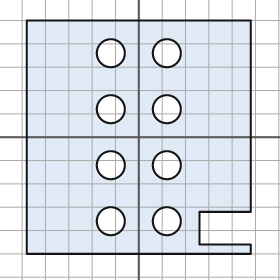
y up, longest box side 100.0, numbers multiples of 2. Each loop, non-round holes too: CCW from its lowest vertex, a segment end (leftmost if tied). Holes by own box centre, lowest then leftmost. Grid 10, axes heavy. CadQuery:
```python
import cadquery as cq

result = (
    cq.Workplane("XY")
    .moveTo(-48.0, -50.0)
    .lineTo(48.0, -50.0)
    .lineTo(48.0, -46.0)
    .lineTo(26.0, -46.0)
    .lineTo(26.0, -32.0)
    .lineTo(48.0, -32.0)
    .lineTo(48.0, 50.0)
    .lineTo(-48.0, 50.0)
    .close()
    .moveTo(-12.0, -36.0)
    .circle(6.0)
    .moveTo(12.0, -36.0)
    .circle(6.0)
    .moveTo(-12.0, -12.0)
    .circle(6.0)
    .moveTo(12.0, -12.0)
    .circle(6.0)
    .moveTo(-12.0, 12.0)
    .circle(6.0)
    .moveTo(12.0, 12.0)
    .circle(6.0)
    .moveTo(-12.0, 36.0)
    .circle(6.0)
    .moveTo(12.0, 36.0)
    .circle(6.0)
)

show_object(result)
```